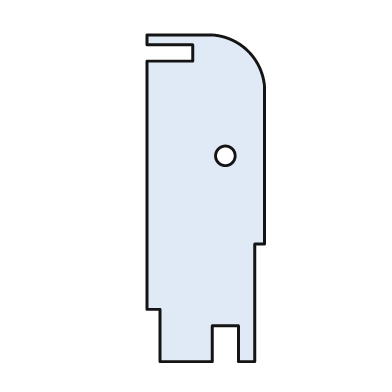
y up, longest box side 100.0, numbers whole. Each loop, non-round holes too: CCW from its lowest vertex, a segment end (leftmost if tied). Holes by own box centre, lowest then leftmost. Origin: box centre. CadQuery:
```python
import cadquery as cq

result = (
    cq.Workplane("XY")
    .moveTo(-14.0, -50.0)
    .lineTo(2.0, -50.0)
    .lineTo(2.0, -39.0)
    .lineTo(10.0, -39.0)
    .lineTo(10.0, -50.0)
    .lineTo(15.0, -50.0)
    .lineTo(15.0, -14.0)
    .lineTo(18.0, -14.0)
    .lineTo(18.0, 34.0)
    .threePointArc((13.0, 45.0), (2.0, 50.0))
    .lineTo(-18.0, 50.0)
    .lineTo(-18.0, 47.0)
    .lineTo(-4.0, 47.0)
    .lineTo(-4.0, 42.0)
    .lineTo(-18.0, 42.0)
    .lineTo(-18.0, -34.0)
    .lineTo(-14.0, -34.0)
    .close()
    .moveTo(6.0, 13.0)
    .circle(3.0)
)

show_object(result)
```